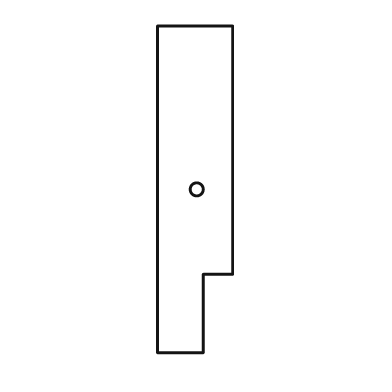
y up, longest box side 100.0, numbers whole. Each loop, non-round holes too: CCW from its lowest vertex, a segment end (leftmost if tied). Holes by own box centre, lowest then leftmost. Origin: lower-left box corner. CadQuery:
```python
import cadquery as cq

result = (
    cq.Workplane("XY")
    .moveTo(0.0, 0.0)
    .lineTo(14.0, 0.0)
    .lineTo(14.0, 24.0)
    .lineTo(23.0, 24.0)
    .lineTo(23.0, 100.0)
    .lineTo(0.0, 100.0)
    .close()
    .moveTo(12.0, 50.0)
    .circle(2.0)
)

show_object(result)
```